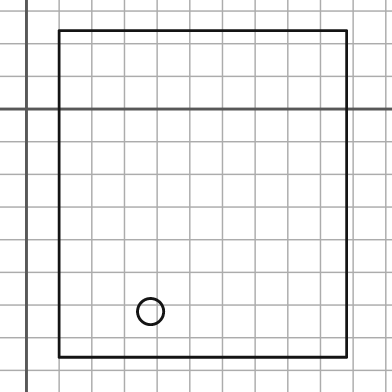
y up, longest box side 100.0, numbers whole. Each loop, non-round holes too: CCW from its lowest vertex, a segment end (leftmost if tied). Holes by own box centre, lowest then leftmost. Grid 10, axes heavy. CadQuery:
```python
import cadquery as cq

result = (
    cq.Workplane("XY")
    .moveTo(10.0, -76.0)
    .lineTo(98.0, -76.0)
    .lineTo(98.0, 24.0)
    .lineTo(10.0, 24.0)
    .close()
    .moveTo(38.0, -62.0)
    .circle(4.0)
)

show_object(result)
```